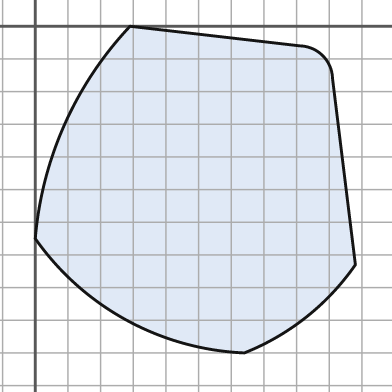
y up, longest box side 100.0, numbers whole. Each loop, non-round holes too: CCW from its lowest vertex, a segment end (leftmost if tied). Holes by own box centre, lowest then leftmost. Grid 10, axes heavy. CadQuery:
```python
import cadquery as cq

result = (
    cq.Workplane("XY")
    .moveTo(64.0, -100.0)
    .threePointArc((83.0, -89.0), (98.0, -73.0))
    .lineTo(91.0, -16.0)
    .threePointArc((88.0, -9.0), (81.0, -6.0))
    .lineTo(29.0, 0.0)
    .threePointArc((9.0, -30.0), (0.0, -65.0))
    .threePointArc((28.0, -90.0), (64.0, -100.0))
    .close()
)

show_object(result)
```